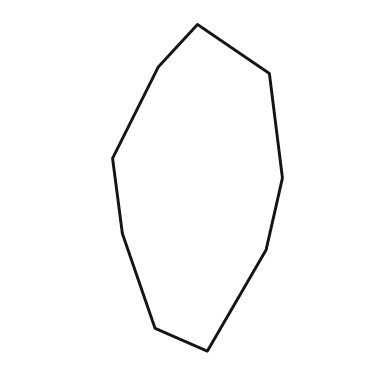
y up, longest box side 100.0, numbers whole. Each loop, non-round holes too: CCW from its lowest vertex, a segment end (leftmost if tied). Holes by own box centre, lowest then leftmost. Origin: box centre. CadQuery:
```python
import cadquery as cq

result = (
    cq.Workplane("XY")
    .moveTo(3.0, -50.0)
    .lineTo(21.0, -19.0)
    .lineTo(26.0, 3.0)
    .lineTo(22.0, 35.0)
    .lineTo(0.0, 50.0)
    .lineTo(-12.0, 37.0)
    .lineTo(-26.0, 9.0)
    .lineTo(-23.0, -14.0)
    .lineTo(-13.0, -43.0)
    .close()
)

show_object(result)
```